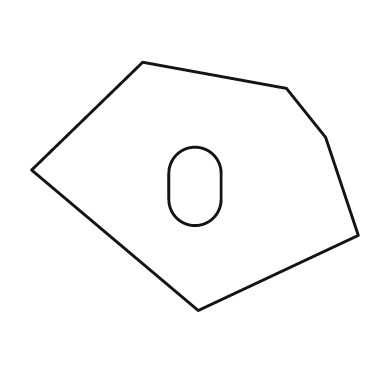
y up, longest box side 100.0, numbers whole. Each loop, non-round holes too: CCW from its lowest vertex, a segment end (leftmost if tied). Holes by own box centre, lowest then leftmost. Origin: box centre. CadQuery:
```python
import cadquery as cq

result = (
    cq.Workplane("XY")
    .moveTo(1.0, -38.0)
    .lineTo(50.0, -15.0)
    .lineTo(40.0, 15.0)
    .lineTo(28.0, 30.0)
    .lineTo(-16.0, 38.0)
    .lineTo(-50.0, 5.0)
    .close()
    .moveTo(-8.0, -4.0)
    .threePointArc((0.0, -12.0), (8.0, -4.0))
    .lineTo(8.0, 4.0)
    .threePointArc((0.0, 12.0), (-8.0, 4.0))
    .close()
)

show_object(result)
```